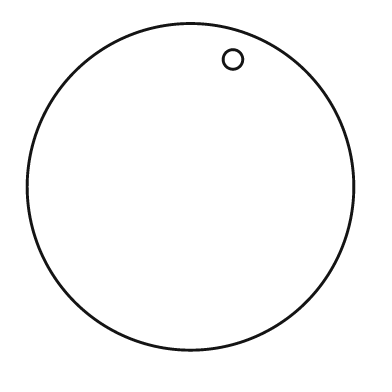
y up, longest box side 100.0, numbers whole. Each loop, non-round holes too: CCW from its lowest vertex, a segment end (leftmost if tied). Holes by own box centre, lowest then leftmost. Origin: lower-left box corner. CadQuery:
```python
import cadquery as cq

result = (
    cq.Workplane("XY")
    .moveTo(50.0, 50.0)
    .circle(50.0)
    .moveTo(63.0, 89.0)
    .circle(3.0)
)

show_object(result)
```